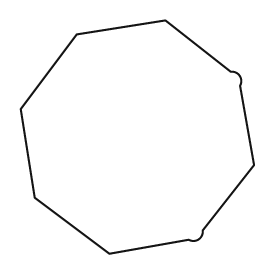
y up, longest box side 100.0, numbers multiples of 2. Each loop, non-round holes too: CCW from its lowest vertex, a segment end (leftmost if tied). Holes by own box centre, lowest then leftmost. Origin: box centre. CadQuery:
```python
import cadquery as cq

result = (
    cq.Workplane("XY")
    .moveTo(-12.0, -50.0)
    .lineTo(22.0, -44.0)
    .threePointArc((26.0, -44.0), (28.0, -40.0))
    .lineTo(50.0, -12.0)
    .lineTo(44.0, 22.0)
    .threePointArc((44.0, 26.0), (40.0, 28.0))
    .lineTo(12.0, 50.0)
    .lineTo(-26.0, 44.0)
    .lineTo(-50.0, 12.0)
    .lineTo(-44.0, -26.0)
    .close()
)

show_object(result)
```